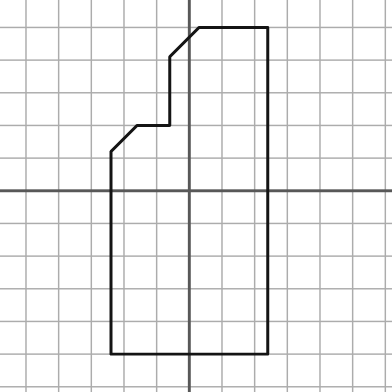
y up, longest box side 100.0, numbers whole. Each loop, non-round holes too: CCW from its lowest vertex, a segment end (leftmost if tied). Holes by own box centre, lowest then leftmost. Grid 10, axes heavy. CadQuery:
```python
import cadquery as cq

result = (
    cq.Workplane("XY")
    .moveTo(-24.0, -50.0)
    .lineTo(24.0, -50.0)
    .lineTo(24.0, 50.0)
    .lineTo(3.0, 50.0)
    .lineTo(-6.0, 41.0)
    .lineTo(-6.0, 20.0)
    .lineTo(-16.0, 20.0)
    .lineTo(-24.0, 12.0)
    .close()
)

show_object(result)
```